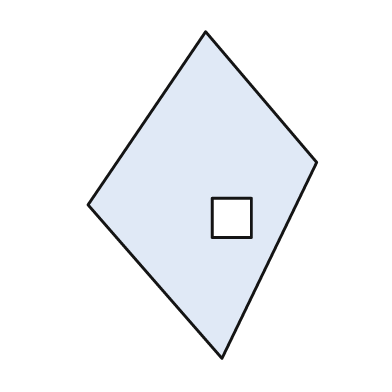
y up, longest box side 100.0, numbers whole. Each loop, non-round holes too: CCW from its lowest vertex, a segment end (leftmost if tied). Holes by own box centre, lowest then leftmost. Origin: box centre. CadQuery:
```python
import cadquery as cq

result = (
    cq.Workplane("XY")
    .moveTo(6.0, -50.0)
    .lineTo(35.0, 10.0)
    .lineTo(1.0, 50.0)
    .lineTo(-35.0, -3.0)
    .close()
    .moveTo(3.0, -13.0)
    .lineTo(15.0, -13.0)
    .lineTo(15.0, -1.0)
    .lineTo(3.0, -1.0)
    .close()
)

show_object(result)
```